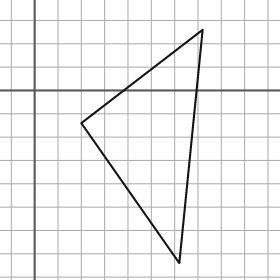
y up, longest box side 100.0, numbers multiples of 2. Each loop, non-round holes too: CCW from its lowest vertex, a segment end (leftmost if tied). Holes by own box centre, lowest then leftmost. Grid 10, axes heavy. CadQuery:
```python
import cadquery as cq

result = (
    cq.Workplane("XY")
    .moveTo(62.0, -74.0)
    .lineTo(72.0, 26.0)
    .lineTo(20.0, -14.0)
    .close()
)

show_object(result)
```